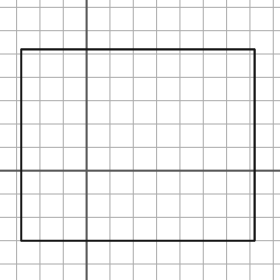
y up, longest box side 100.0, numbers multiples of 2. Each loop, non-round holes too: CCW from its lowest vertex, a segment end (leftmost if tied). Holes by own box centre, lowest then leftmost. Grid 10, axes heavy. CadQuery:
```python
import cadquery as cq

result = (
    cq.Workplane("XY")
    .moveTo(-28.0, -30.0)
    .lineTo(72.0, -30.0)
    .lineTo(72.0, 52.0)
    .lineTo(-28.0, 52.0)
    .close()
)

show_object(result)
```